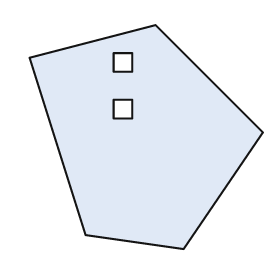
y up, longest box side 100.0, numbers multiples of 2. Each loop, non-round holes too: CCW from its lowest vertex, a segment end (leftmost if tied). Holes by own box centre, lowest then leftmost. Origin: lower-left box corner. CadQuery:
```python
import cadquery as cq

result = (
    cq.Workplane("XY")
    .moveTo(66.0, 0.0)
    .lineTo(100.0, 50.0)
    .lineTo(54.0, 96.0)
    .lineTo(0.0, 82.0)
    .lineTo(24.0, 6.0)
    .close()
    .moveTo(36.0, 56.0)
    .lineTo(44.0, 56.0)
    .lineTo(44.0, 64.0)
    .lineTo(36.0, 64.0)
    .close()
    .moveTo(36.0, 76.0)
    .lineTo(44.0, 76.0)
    .lineTo(44.0, 84.0)
    .lineTo(36.0, 84.0)
    .close()
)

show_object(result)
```